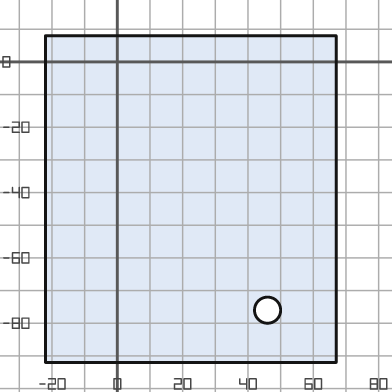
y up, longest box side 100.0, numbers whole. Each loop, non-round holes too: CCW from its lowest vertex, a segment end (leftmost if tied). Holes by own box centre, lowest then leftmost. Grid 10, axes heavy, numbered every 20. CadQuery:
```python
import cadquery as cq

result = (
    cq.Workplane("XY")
    .moveTo(-22.0, -92.0)
    .lineTo(67.0, -92.0)
    .lineTo(67.0, 8.0)
    .lineTo(-22.0, 8.0)
    .close()
    .moveTo(46.0, -76.0)
    .circle(4.0)
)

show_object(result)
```